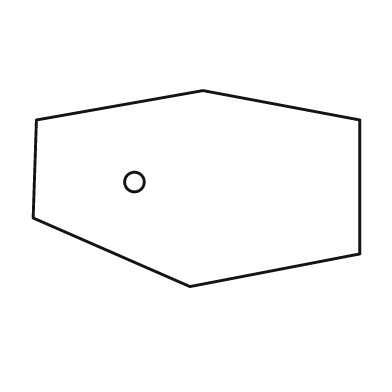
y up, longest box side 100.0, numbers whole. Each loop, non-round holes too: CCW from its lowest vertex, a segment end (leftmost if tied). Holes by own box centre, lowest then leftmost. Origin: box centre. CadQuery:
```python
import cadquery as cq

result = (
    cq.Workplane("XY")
    .moveTo(-2.0, -30.0)
    .lineTo(50.0, -20.0)
    .lineTo(50.0, 21.0)
    .lineTo(2.0, 30.0)
    .lineTo(-49.0, 21.0)
    .lineTo(-50.0, -9.0)
    .close()
    .moveTo(-19.0, 2.0)
    .circle(3.0)
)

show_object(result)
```